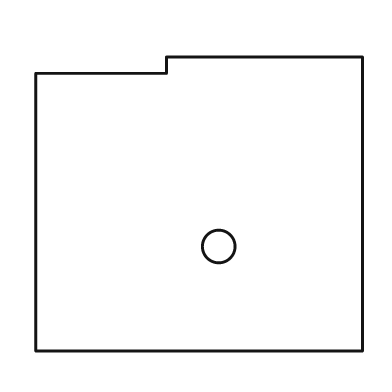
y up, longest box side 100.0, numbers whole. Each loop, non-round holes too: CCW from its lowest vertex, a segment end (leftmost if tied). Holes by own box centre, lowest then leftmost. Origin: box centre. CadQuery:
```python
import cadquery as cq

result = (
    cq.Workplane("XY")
    .moveTo(-50.0, -45.0)
    .lineTo(50.0, -45.0)
    .lineTo(50.0, 45.0)
    .lineTo(-10.0, 45.0)
    .lineTo(-10.0, 40.0)
    .lineTo(-50.0, 40.0)
    .close()
    .moveTo(6.0, -13.0)
    .circle(5.0)
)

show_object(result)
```